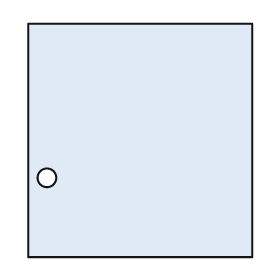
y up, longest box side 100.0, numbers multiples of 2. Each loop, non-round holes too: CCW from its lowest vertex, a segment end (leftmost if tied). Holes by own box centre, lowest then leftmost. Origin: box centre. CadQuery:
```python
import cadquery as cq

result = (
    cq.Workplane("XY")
    .moveTo(-48.0, -50.0)
    .lineTo(48.0, -50.0)
    .lineTo(48.0, 50.0)
    .lineTo(-48.0, 50.0)
    .close()
    .moveTo(-40.0, -16.0)
    .circle(4.0)
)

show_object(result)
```